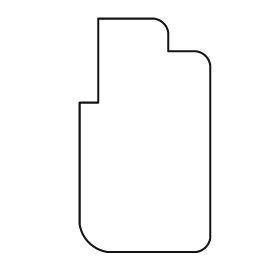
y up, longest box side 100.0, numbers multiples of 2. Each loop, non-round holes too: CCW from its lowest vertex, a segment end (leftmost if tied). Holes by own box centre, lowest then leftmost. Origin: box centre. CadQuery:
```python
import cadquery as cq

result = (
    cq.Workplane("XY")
    .moveTo(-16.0, -50.0)
    .lineTo(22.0, -50.0)
    .threePointArc((26.0, -48.0), (28.0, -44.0))
    .lineTo(28.0, 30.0)
    .threePointArc((26.0, 34.0), (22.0, 36.0))
    .lineTo(10.0, 36.0)
    .lineTo(10.0, 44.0)
    .threePointArc((8.0, 48.0), (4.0, 50.0))
    .lineTo(-20.0, 50.0)
    .lineTo(-20.0, 14.0)
    .lineTo(-28.0, 14.0)
    .lineTo(-28.0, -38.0)
    .threePointArc((-24.0, -46.0), (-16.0, -50.0))
    .close()
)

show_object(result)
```